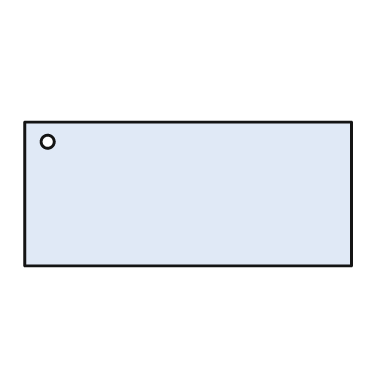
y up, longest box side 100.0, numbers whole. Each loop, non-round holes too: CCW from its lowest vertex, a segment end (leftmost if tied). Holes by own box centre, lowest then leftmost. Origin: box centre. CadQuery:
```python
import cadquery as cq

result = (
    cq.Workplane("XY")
    .moveTo(-50.0, -22.0)
    .lineTo(50.0, -22.0)
    .lineTo(50.0, 22.0)
    .lineTo(-50.0, 22.0)
    .close()
    .moveTo(-43.0, 16.0)
    .circle(2.0)
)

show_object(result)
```